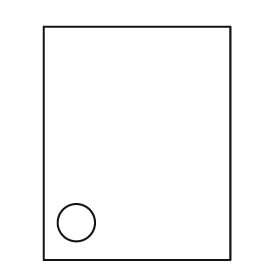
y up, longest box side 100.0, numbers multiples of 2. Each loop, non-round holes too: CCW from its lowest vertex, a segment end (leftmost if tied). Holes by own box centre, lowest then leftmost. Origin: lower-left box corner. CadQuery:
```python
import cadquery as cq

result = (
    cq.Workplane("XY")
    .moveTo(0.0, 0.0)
    .lineTo(80.0, 0.0)
    .lineTo(80.0, 100.0)
    .lineTo(0.0, 100.0)
    .close()
    .moveTo(14.0, 16.0)
    .circle(8.0)
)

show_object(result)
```